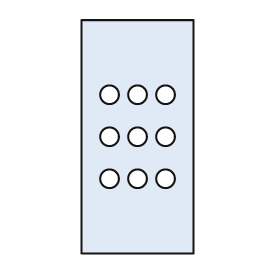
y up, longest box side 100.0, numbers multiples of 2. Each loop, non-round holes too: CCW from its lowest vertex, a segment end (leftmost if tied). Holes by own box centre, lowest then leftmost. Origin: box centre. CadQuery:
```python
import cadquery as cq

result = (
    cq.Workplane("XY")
    .moveTo(-24.0, -50.0)
    .lineTo(24.0, -50.0)
    .lineTo(24.0, 50.0)
    .lineTo(-24.0, 50.0)
    .close()
    .moveTo(-12.0, -18.0)
    .circle(4.0)
    .moveTo(0.0, -18.0)
    .circle(4.0)
    .moveTo(12.0, -18.0)
    .circle(4.0)
    .moveTo(-12.0, 0.0)
    .circle(4.0)
    .moveTo(0.0, 0.0)
    .circle(4.0)
    .moveTo(12.0, 0.0)
    .circle(4.0)
    .moveTo(-12.0, 18.0)
    .circle(4.0)
    .moveTo(0.0, 18.0)
    .circle(4.0)
    .moveTo(12.0, 18.0)
    .circle(4.0)
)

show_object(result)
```